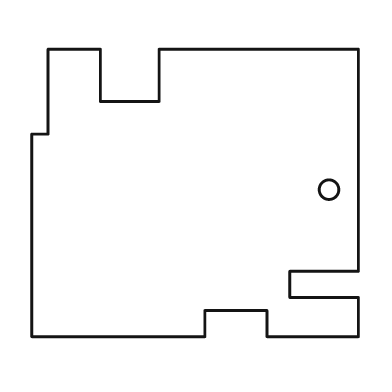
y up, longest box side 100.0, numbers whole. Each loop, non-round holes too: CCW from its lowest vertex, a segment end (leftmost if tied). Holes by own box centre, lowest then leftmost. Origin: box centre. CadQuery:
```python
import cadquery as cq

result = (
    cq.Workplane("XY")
    .moveTo(-50.0, -44.0)
    .lineTo(3.0, -44.0)
    .lineTo(3.0, -36.0)
    .lineTo(22.0, -36.0)
    .lineTo(22.0, -44.0)
    .lineTo(50.0, -44.0)
    .lineTo(50.0, -32.0)
    .lineTo(29.0, -32.0)
    .lineTo(29.0, -24.0)
    .lineTo(50.0, -24.0)
    .lineTo(50.0, 44.0)
    .lineTo(-11.0, 44.0)
    .lineTo(-11.0, 28.0)
    .lineTo(-29.0, 28.0)
    .lineTo(-29.0, 44.0)
    .lineTo(-45.0, 44.0)
    .lineTo(-45.0, 18.0)
    .lineTo(-50.0, 18.0)
    .close()
    .moveTo(41.0, 1.0)
    .circle(3.0)
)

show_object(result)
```